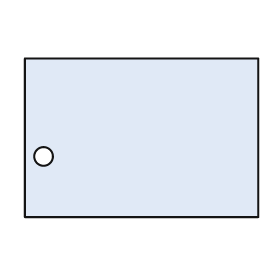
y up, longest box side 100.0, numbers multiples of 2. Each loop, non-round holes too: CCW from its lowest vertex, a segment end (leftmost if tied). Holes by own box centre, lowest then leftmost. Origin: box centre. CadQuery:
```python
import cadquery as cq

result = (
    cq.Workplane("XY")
    .moveTo(-50.0, -34.0)
    .lineTo(50.0, -34.0)
    .lineTo(50.0, 34.0)
    .lineTo(-50.0, 34.0)
    .close()
    .moveTo(-42.0, -8.0)
    .circle(4.0)
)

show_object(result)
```